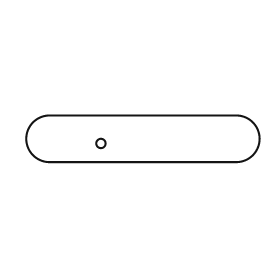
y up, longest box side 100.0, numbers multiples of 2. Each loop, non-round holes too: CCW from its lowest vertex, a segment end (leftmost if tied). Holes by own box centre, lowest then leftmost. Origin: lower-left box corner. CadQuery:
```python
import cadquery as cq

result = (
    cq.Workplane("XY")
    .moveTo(10.0, 0.0)
    .lineTo(90.0, 0.0)
    .threePointArc((100.0, 10.0), (90.0, 20.0))
    .lineTo(10.0, 20.0)
    .threePointArc((0.0, 10.0), (10.0, 0.0))
    .close()
    .moveTo(32.0, 8.0)
    .circle(2.0)
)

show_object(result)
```